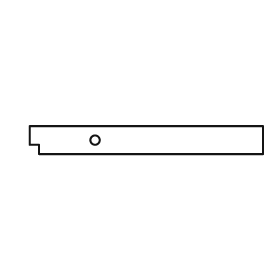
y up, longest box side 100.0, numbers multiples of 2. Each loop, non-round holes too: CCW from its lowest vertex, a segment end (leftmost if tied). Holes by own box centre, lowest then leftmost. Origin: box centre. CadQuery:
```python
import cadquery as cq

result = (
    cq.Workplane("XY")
    .moveTo(-46.0, -6.0)
    .lineTo(50.0, -6.0)
    .lineTo(50.0, 6.0)
    .lineTo(-50.0, 6.0)
    .lineTo(-50.0, -2.0)
    .lineTo(-46.0, -2.0)
    .close()
    .moveTo(-22.0, 0.0)
    .circle(2.0)
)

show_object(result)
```